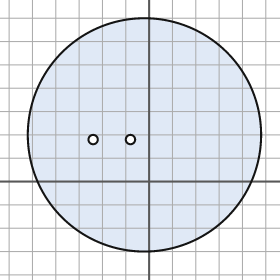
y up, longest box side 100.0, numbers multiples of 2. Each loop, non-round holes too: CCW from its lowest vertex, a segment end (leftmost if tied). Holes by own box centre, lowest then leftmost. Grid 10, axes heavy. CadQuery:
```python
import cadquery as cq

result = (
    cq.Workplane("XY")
    .moveTo(-2.0, 20.0)
    .circle(50.0)
    .moveTo(-24.0, 18.0)
    .circle(2.0)
    .moveTo(-8.0, 18.0)
    .circle(2.0)
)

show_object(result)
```